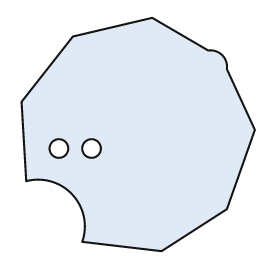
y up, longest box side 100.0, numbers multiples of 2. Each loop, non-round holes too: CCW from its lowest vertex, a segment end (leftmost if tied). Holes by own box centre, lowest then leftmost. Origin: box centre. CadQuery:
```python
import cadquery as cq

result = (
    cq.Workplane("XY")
    .moveTo(10.0, -50.0)
    .lineTo(38.0, -32.0)
    .lineTo(50.0, 2.0)
    .lineTo(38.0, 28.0)
    .threePointArc((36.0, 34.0), (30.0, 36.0))
    .lineTo(6.0, 50.0)
    .lineTo(-28.0, 42.0)
    .lineTo(-50.0, 14.0)
    .lineTo(-48.0, -20.0)
    .threePointArc((-28.0, -26.0), (-24.0, -46.0))
    .close()
    .moveTo(-34.0, -6.0)
    .circle(4.0)
    .moveTo(-20.0, -6.0)
    .circle(4.0)
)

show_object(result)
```